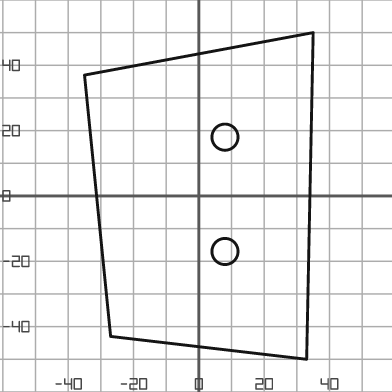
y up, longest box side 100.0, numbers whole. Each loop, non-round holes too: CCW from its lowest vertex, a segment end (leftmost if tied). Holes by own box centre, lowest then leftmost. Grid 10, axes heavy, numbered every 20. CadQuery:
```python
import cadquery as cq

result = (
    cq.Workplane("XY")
    .moveTo(33.0, -50.0)
    .lineTo(35.0, 50.0)
    .lineTo(-35.0, 37.0)
    .lineTo(-27.0, -43.0)
    .close()
    .moveTo(8.0, -17.0)
    .circle(4.0)
    .moveTo(8.0, 18.0)
    .circle(4.0)
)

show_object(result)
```